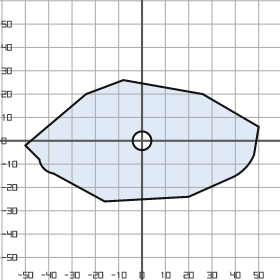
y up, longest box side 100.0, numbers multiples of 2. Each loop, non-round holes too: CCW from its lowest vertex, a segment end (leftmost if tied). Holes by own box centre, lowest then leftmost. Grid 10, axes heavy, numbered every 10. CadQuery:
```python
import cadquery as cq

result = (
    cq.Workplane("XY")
    .moveTo(-16.0, -26.0)
    .lineTo(20.0, -24.0)
    .lineTo(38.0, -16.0)
    .threePointArc((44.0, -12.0), (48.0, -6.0))
    .lineTo(50.0, 6.0)
    .lineTo(26.0, 20.0)
    .lineTo(-8.0, 26.0)
    .lineTo(-24.0, 20.0)
    .lineTo(-50.0, -2.0)
    .lineTo(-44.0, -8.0)
    .threePointArc((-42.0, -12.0), (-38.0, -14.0))
    .close()
    .moveTo(0.0, 0.0)
    .circle(4.0)
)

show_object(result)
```